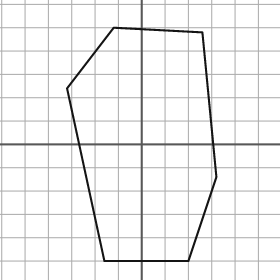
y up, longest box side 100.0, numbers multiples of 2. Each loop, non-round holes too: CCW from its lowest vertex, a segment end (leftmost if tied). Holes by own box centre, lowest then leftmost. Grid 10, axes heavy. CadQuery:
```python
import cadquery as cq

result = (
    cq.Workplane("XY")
    .moveTo(-16.0, -50.0)
    .lineTo(20.0, -50.0)
    .lineTo(32.0, -14.0)
    .lineTo(26.0, 48.0)
    .lineTo(-12.0, 50.0)
    .lineTo(-32.0, 24.0)
    .close()
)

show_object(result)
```